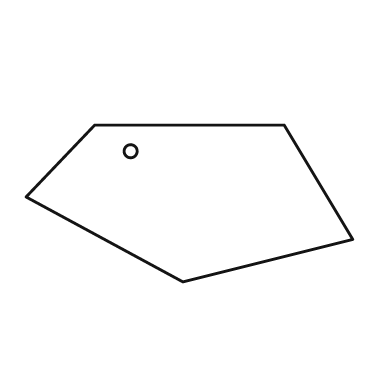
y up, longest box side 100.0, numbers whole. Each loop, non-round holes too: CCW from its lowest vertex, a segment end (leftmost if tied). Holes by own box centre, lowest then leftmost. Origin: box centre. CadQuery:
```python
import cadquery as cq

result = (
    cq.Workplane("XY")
    .moveTo(-2.0, -24.0)
    .lineTo(50.0, -11.0)
    .lineTo(29.0, 24.0)
    .lineTo(-29.0, 24.0)
    .lineTo(-50.0, 2.0)
    .close()
    .moveTo(-18.0, 16.0)
    .circle(2.0)
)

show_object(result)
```